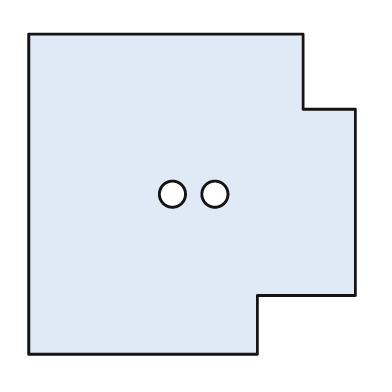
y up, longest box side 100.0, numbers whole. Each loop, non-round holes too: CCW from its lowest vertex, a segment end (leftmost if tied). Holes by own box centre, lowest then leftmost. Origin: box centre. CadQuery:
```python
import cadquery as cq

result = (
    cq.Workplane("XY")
    .moveTo(-50.0, -49.0)
    .lineTo(20.0, -49.0)
    .lineTo(20.0, -31.0)
    .lineTo(50.0, -31.0)
    .lineTo(50.0, 26.0)
    .lineTo(34.0, 26.0)
    .lineTo(34.0, 49.0)
    .lineTo(-50.0, 49.0)
    .close()
    .moveTo(-6.0, 0.0)
    .circle(4.0)
    .moveTo(7.0, 0.0)
    .circle(4.0)
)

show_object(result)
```